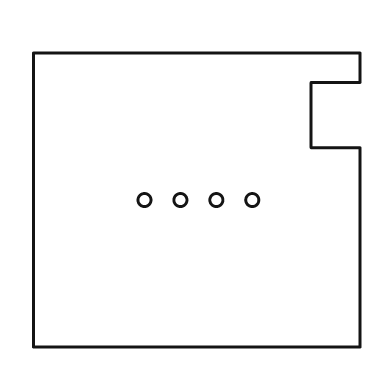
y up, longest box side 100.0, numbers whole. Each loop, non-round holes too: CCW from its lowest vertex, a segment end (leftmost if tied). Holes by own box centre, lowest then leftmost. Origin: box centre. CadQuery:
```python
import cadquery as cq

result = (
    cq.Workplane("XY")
    .moveTo(-50.0, -45.0)
    .lineTo(50.0, -45.0)
    .lineTo(50.0, 16.0)
    .lineTo(35.0, 16.0)
    .lineTo(35.0, 36.0)
    .lineTo(50.0, 36.0)
    .lineTo(50.0, 45.0)
    .lineTo(-50.0, 45.0)
    .close()
    .moveTo(-16.0, 0.0)
    .circle(2.0)
    .moveTo(-5.0, 0.0)
    .circle(2.0)
    .moveTo(6.0, 0.0)
    .circle(2.0)
    .moveTo(17.0, 0.0)
    .circle(2.0)
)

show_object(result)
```